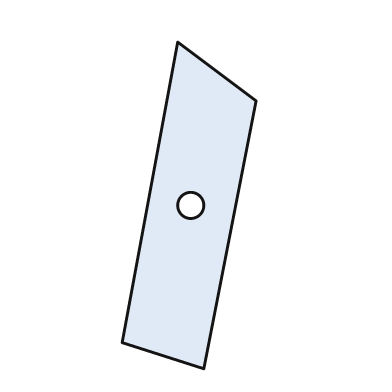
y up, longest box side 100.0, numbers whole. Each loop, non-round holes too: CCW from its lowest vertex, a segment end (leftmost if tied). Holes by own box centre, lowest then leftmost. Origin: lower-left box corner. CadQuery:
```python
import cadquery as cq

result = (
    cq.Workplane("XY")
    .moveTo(25.0, 0.0)
    .lineTo(41.0, 82.0)
    .lineTo(17.0, 100.0)
    .lineTo(0.0, 8.0)
    .close()
    .moveTo(21.0, 50.0)
    .circle(4.0)
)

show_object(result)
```